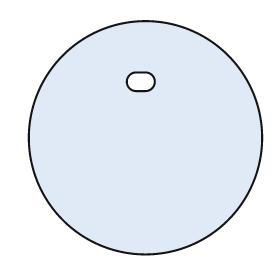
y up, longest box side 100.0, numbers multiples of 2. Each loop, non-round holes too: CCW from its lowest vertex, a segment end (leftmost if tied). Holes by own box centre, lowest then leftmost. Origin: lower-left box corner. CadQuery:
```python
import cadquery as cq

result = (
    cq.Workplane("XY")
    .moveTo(50.0, 50.0)
    .circle(50.0)
    .moveTo(46.0, 70.0)
    .lineTo(50.0, 70.0)
    .threePointArc((54.0, 74.0), (50.0, 78.0))
    .lineTo(46.0, 78.0)
    .threePointArc((42.0, 74.0), (46.0, 70.0))
    .close()
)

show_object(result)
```